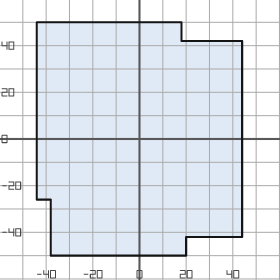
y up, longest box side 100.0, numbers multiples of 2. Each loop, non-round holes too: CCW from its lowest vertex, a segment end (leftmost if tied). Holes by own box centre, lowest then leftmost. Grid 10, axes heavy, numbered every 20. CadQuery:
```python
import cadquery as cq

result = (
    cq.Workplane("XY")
    .moveTo(-38.0, -50.0)
    .lineTo(20.0, -50.0)
    .lineTo(20.0, -42.0)
    .lineTo(44.0, -42.0)
    .lineTo(44.0, 42.0)
    .lineTo(18.0, 42.0)
    .lineTo(18.0, 50.0)
    .lineTo(-44.0, 50.0)
    .lineTo(-44.0, -26.0)
    .lineTo(-38.0, -26.0)
    .close()
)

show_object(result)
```